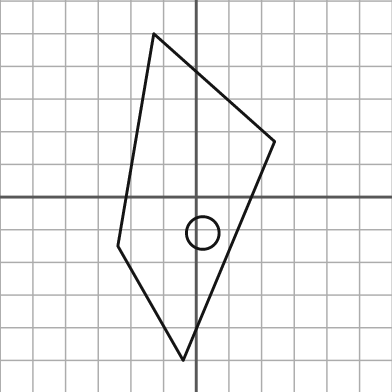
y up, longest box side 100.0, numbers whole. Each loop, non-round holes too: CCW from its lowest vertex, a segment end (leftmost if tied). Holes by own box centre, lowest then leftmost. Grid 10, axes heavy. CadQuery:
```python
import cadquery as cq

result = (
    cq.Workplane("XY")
    .moveTo(-4.0, -50.0)
    .lineTo(24.0, 17.0)
    .lineTo(-13.0, 50.0)
    .lineTo(-24.0, -15.0)
    .close()
    .moveTo(2.0, -11.0)
    .circle(5.0)
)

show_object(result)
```